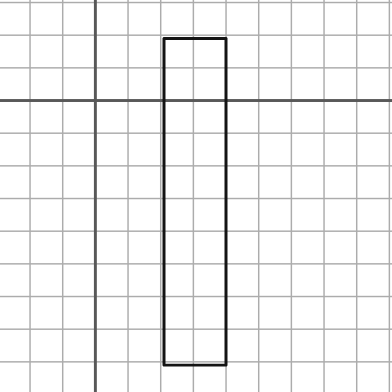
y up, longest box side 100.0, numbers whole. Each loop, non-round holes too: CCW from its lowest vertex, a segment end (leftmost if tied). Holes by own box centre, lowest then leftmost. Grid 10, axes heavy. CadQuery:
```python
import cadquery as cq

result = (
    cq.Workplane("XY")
    .moveTo(21.0, -81.0)
    .lineTo(40.0, -81.0)
    .lineTo(40.0, 19.0)
    .lineTo(21.0, 19.0)
    .close()
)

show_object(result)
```